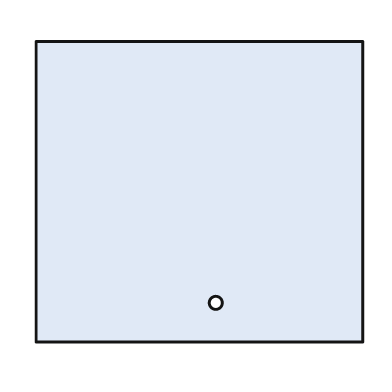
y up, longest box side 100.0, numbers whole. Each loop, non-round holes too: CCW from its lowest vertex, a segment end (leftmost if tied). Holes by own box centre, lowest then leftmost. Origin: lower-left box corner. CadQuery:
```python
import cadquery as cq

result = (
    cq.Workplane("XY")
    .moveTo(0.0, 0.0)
    .lineTo(100.0, 0.0)
    .lineTo(100.0, 92.0)
    .lineTo(0.0, 92.0)
    .close()
    .moveTo(55.0, 12.0)
    .circle(2.0)
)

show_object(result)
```